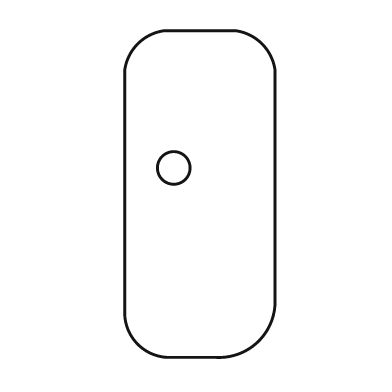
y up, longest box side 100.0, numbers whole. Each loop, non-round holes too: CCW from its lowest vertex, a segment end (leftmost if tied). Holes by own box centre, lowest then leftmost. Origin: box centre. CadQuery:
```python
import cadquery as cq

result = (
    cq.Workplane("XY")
    .moveTo(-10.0, -50.0)
    .lineTo(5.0, -50.0)
    .threePointArc((18.0, -45.0), (23.0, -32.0))
    .lineTo(23.0, 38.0)
    .threePointArc((19.0, 46.0), (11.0, 50.0))
    .lineTo(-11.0, 50.0)
    .threePointArc((-19.0, 46.0), (-23.0, 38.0))
    .lineTo(-23.0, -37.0)
    .threePointArc((-19.0, -46.0), (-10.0, -50.0))
    .close()
    .moveTo(-8.0, 8.0)
    .circle(5.0)
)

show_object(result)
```